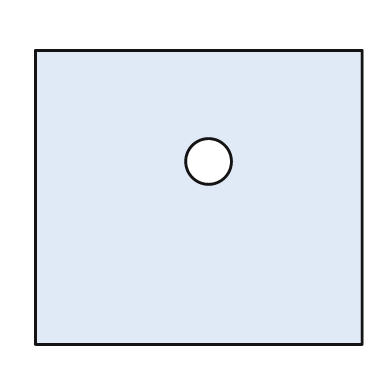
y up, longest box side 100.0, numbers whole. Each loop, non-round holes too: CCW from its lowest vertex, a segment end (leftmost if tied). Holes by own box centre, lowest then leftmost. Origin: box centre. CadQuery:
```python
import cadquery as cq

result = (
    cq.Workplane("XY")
    .moveTo(-50.0, -45.0)
    .lineTo(50.0, -45.0)
    .lineTo(50.0, 45.0)
    .lineTo(-50.0, 45.0)
    .close()
    .moveTo(3.0, 11.0)
    .circle(7.0)
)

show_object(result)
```